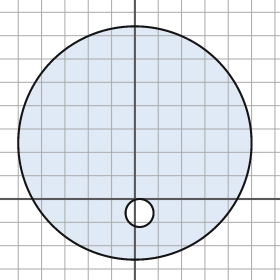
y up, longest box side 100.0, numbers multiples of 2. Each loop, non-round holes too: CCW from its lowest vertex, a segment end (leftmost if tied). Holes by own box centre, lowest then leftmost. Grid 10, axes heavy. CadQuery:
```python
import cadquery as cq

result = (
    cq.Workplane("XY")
    .moveTo(0.0, 24.0)
    .circle(50.0)
    .moveTo(2.0, -6.0)
    .circle(6.0)
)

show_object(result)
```